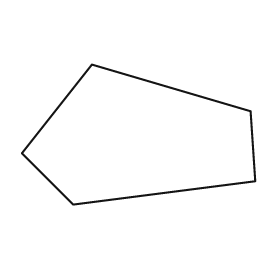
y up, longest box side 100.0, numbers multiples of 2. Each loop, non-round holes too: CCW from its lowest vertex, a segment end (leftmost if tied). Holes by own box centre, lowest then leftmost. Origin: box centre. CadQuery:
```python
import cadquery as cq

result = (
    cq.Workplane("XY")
    .moveTo(-28.0, -30.0)
    .lineTo(50.0, -20.0)
    .lineTo(48.0, 10.0)
    .lineTo(-20.0, 30.0)
    .lineTo(-50.0, -8.0)
    .close()
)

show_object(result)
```